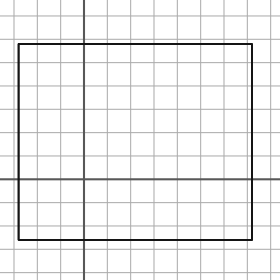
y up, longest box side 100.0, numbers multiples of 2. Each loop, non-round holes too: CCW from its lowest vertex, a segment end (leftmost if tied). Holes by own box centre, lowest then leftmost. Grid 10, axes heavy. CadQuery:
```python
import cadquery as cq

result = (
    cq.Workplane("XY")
    .moveTo(-28.0, -26.0)
    .lineTo(72.0, -26.0)
    .lineTo(72.0, 58.0)
    .lineTo(-28.0, 58.0)
    .close()
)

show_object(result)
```